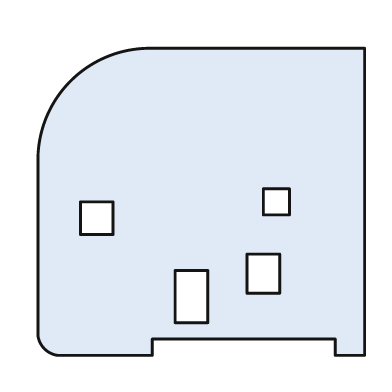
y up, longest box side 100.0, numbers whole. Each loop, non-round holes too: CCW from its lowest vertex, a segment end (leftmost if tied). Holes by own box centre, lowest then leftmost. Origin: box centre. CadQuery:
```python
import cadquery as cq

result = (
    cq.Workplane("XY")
    .moveTo(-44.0, -47.0)
    .lineTo(-15.0, -47.0)
    .lineTo(-15.0, -42.0)
    .lineTo(41.0, -42.0)
    .lineTo(41.0, -47.0)
    .lineTo(50.0, -47.0)
    .lineTo(50.0, 47.0)
    .lineTo(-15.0, 47.0)
    .threePointArc((-40.0, 37.0), (-50.0, 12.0))
    .lineTo(-50.0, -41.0)
    .threePointArc((-48.0, -45.0), (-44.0, -47.0))
    .close()
    .moveTo(-8.0, -37.0)
    .lineTo(2.0, -37.0)
    .lineTo(2.0, -21.0)
    .lineTo(-8.0, -21.0)
    .close()
    .moveTo(14.0, -28.0)
    .lineTo(24.0, -28.0)
    .lineTo(24.0, -16.0)
    .lineTo(14.0, -16.0)
    .close()
    .moveTo(-37.0, -10.0)
    .lineTo(-27.0, -10.0)
    .lineTo(-27.0, 0.0)
    .lineTo(-37.0, 0.0)
    .close()
    .moveTo(19.0, -4.0)
    .lineTo(27.0, -4.0)
    .lineTo(27.0, 4.0)
    .lineTo(19.0, 4.0)
    .close()
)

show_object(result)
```